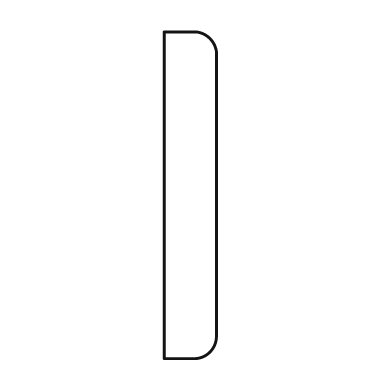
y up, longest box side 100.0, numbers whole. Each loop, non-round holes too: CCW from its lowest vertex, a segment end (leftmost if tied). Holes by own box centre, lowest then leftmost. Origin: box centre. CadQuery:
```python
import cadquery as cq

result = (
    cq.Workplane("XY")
    .moveTo(-8.0, -50.0)
    .lineTo(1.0, -50.0)
    .threePointArc((6.0, -48.0), (8.0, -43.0))
    .lineTo(8.0, 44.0)
    .threePointArc((6.0, 48.0), (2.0, 50.0))
    .lineTo(-8.0, 50.0)
    .close()
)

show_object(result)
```